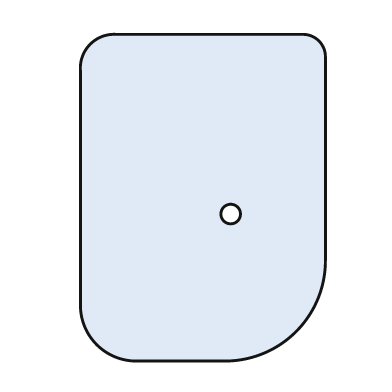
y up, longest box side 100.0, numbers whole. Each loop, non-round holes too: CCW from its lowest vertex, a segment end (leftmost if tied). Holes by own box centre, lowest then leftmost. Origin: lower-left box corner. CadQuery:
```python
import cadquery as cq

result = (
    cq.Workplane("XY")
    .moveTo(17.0, 0.0)
    .lineTo(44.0, 0.0)
    .threePointArc((66.0, 9.0), (75.0, 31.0))
    .lineTo(75.0, 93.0)
    .threePointArc((73.0, 98.0), (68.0, 100.0))
    .lineTo(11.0, 100.0)
    .threePointArc((3.0, 97.0), (0.0, 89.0))
    .lineTo(0.0, 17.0)
    .threePointArc((5.0, 5.0), (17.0, 0.0))
    .close()
    .moveTo(46.0, 45.0)
    .circle(3.0)
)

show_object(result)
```